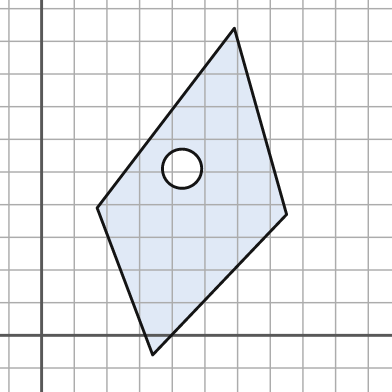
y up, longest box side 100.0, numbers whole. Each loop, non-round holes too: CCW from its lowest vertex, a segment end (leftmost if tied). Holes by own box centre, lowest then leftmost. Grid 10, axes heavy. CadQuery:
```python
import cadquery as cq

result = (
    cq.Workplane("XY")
    .moveTo(34.0, -6.0)
    .lineTo(75.0, 37.0)
    .lineTo(59.0, 94.0)
    .lineTo(17.0, 39.0)
    .close()
    .moveTo(43.0, 51.0)
    .circle(6.0)
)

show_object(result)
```